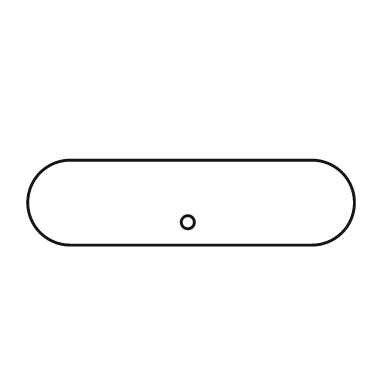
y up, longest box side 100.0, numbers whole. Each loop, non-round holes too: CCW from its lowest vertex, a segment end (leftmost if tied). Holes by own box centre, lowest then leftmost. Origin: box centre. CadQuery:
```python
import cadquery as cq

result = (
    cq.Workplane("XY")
    .moveTo(-37.0, -13.0)
    .lineTo(37.0, -13.0)
    .threePointArc((50.0, 0.0), (37.0, 13.0))
    .lineTo(-37.0, 13.0)
    .threePointArc((-50.0, 0.0), (-37.0, -13.0))
    .close()
    .moveTo(-1.0, -6.0)
    .circle(2.0)
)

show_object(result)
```